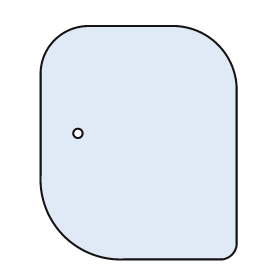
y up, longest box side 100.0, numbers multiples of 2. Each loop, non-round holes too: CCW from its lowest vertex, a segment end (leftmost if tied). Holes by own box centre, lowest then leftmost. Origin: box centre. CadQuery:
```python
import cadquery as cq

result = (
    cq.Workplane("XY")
    .moveTo(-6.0, -50.0)
    .lineTo(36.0, -50.0)
    .threePointArc((40.0, -48.0), (42.0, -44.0))
    .lineTo(42.0, 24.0)
    .threePointArc((34.0, 42.0), (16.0, 50.0))
    .lineTo(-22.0, 50.0)
    .threePointArc((-36.0, 44.0), (-42.0, 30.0))
    .lineTo(-42.0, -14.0)
    .threePointArc((-32.0, -40.0), (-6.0, -50.0))
    .close()
    .moveTo(-26.0, 4.0)
    .circle(2.0)
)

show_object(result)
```